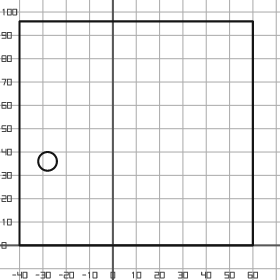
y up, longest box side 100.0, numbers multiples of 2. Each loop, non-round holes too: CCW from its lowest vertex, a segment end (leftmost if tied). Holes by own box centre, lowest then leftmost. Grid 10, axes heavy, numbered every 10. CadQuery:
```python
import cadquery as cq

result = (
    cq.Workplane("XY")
    .moveTo(-40.0, 0.0)
    .lineTo(60.0, 0.0)
    .lineTo(60.0, 96.0)
    .lineTo(-40.0, 96.0)
    .close()
    .moveTo(-28.0, 36.0)
    .circle(4.0)
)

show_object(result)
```